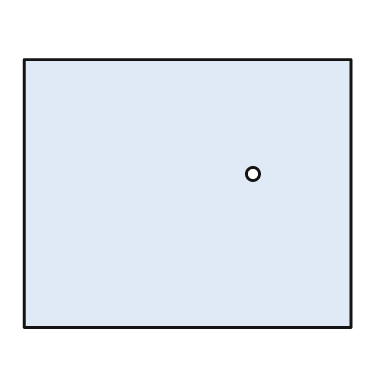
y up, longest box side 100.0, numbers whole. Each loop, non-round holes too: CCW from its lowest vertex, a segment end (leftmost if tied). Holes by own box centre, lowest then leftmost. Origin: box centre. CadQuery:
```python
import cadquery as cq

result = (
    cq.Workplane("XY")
    .moveTo(-50.0, -41.0)
    .lineTo(50.0, -41.0)
    .lineTo(50.0, 41.0)
    .lineTo(-50.0, 41.0)
    .close()
    .moveTo(20.0, 6.0)
    .circle(2.0)
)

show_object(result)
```